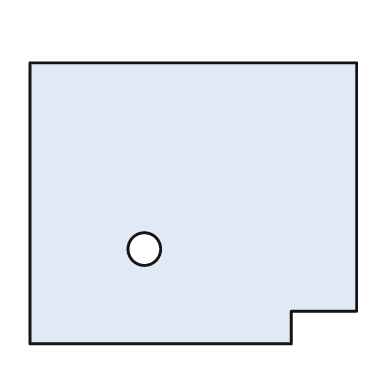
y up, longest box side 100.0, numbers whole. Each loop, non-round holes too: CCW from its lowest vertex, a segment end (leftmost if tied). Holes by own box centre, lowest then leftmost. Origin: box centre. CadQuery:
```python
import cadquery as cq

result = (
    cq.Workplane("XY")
    .moveTo(-50.0, -43.0)
    .lineTo(30.0, -43.0)
    .lineTo(30.0, -33.0)
    .lineTo(50.0, -33.0)
    .lineTo(50.0, 43.0)
    .lineTo(-50.0, 43.0)
    .close()
    .moveTo(-15.0, -14.0)
    .circle(5.0)
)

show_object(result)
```